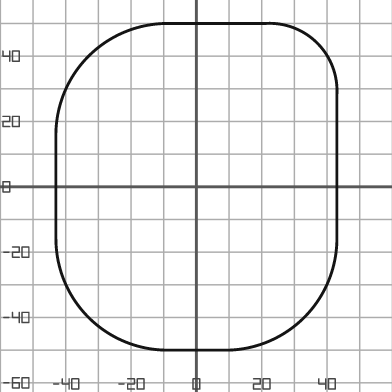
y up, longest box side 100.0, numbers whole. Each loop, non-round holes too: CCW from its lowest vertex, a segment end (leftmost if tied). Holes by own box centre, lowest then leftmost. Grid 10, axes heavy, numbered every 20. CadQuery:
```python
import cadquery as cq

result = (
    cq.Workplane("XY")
    .moveTo(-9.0, -50.0)
    .lineTo(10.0, -50.0)
    .threePointArc((33.0, -40.0), (43.0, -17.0))
    .lineTo(43.0, 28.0)
    .threePointArc((37.0, 44.0), (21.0, 50.0))
    .lineTo(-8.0, 50.0)
    .threePointArc((-33.0, 40.0), (-43.0, 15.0))
    .lineTo(-43.0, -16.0)
    .threePointArc((-33.0, -40.0), (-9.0, -50.0))
    .close()
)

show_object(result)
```